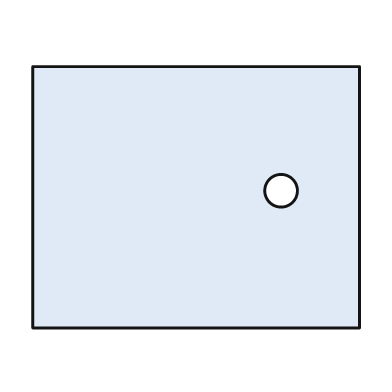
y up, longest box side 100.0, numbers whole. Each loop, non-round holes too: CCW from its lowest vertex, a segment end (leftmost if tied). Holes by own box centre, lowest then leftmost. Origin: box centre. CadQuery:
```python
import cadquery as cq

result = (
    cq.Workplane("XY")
    .moveTo(-50.0, -40.0)
    .lineTo(50.0, -40.0)
    .lineTo(50.0, 40.0)
    .lineTo(-50.0, 40.0)
    .close()
    .moveTo(26.0, 2.0)
    .circle(5.0)
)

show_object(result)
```